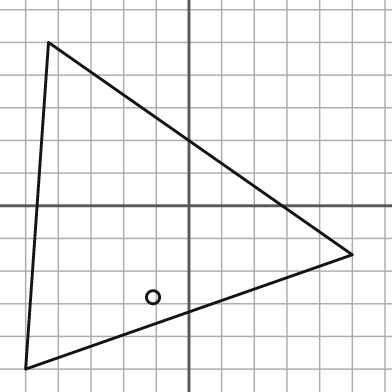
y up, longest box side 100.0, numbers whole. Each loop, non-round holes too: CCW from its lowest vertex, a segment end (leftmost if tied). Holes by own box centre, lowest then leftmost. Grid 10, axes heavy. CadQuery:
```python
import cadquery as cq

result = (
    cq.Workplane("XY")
    .moveTo(-50.0, -50.0)
    .lineTo(50.0, -15.0)
    .lineTo(-43.0, 50.0)
    .close()
    .moveTo(-11.0, -28.0)
    .circle(2.0)
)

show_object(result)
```